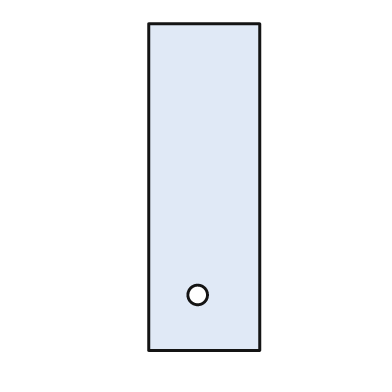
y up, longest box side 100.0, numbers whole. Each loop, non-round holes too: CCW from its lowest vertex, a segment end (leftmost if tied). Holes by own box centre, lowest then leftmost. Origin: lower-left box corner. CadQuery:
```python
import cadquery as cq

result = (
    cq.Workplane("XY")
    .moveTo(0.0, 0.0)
    .lineTo(34.0, 0.0)
    .lineTo(34.0, 100.0)
    .lineTo(0.0, 100.0)
    .close()
    .moveTo(15.0, 17.0)
    .circle(3.0)
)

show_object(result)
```